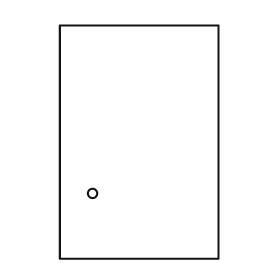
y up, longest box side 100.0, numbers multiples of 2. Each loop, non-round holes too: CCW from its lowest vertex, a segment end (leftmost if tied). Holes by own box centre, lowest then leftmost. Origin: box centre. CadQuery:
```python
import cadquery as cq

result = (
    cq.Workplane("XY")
    .moveTo(-34.0, -50.0)
    .lineTo(34.0, -50.0)
    .lineTo(34.0, 50.0)
    .lineTo(-34.0, 50.0)
    .close()
    .moveTo(-20.0, -22.0)
    .circle(2.0)
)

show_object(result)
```